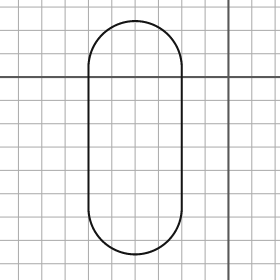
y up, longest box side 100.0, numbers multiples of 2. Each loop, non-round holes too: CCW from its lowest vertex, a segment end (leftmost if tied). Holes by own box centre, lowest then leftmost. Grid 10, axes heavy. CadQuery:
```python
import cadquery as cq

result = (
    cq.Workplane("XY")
    .moveTo(-60.0, -56.0)
    .threePointArc((-40.0, -76.0), (-20.0, -56.0))
    .lineTo(-20.0, 4.0)
    .threePointArc((-40.0, 24.0), (-60.0, 4.0))
    .close()
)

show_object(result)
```